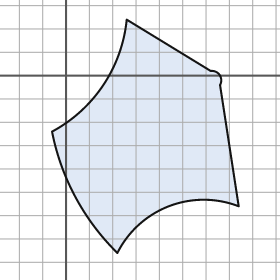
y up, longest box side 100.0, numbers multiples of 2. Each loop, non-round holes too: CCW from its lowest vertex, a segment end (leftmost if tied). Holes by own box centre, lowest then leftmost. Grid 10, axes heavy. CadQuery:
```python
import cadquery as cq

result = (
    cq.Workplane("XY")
    .moveTo(22.0, -76.0)
    .threePointArc((44.0, -56.0), (74.0, -56.0))
    .lineTo(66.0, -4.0)
    .threePointArc((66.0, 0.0), (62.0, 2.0))
    .lineTo(26.0, 24.0)
    .threePointArc((16.0, -4.0), (-6.0, -24.0))
    .threePointArc((4.0, -52.0), (22.0, -76.0))
    .close()
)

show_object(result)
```